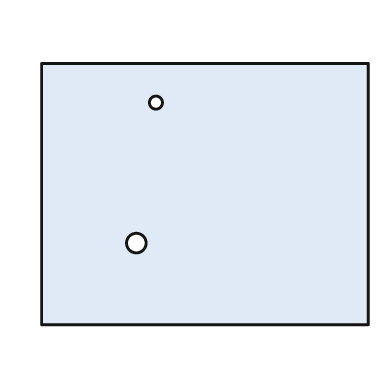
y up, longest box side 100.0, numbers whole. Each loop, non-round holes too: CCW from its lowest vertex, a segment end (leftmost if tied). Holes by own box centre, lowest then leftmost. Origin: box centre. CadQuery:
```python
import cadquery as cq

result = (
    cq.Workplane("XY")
    .moveTo(-50.0, -40.0)
    .lineTo(50.0, -40.0)
    .lineTo(50.0, 40.0)
    .lineTo(-50.0, 40.0)
    .close()
    .moveTo(-21.0, -15.0)
    .circle(3.0)
    .moveTo(-15.0, 28.0)
    .circle(2.0)
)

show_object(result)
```